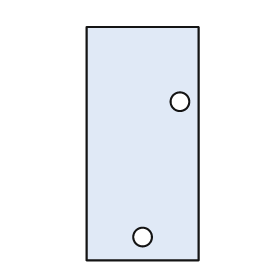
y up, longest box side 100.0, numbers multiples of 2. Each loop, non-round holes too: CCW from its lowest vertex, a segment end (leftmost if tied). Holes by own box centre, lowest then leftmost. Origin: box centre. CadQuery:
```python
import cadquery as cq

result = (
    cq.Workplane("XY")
    .moveTo(-24.0, -50.0)
    .lineTo(24.0, -50.0)
    .lineTo(24.0, 50.0)
    .lineTo(-24.0, 50.0)
    .close()
    .moveTo(0.0, -40.0)
    .circle(4.0)
    .moveTo(16.0, 18.0)
    .circle(4.0)
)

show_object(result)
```